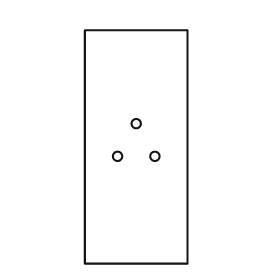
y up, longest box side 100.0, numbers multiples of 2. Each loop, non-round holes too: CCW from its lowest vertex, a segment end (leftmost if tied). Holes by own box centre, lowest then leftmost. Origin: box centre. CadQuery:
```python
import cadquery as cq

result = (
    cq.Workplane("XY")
    .moveTo(-22.0, -50.0)
    .lineTo(22.0, -50.0)
    .lineTo(22.0, 50.0)
    .lineTo(-22.0, 50.0)
    .close()
    .moveTo(-8.0, -4.0)
    .circle(2.0)
    .moveTo(8.0, -4.0)
    .circle(2.0)
    .moveTo(0.0, 10.0)
    .circle(2.0)
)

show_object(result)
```